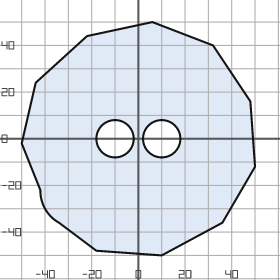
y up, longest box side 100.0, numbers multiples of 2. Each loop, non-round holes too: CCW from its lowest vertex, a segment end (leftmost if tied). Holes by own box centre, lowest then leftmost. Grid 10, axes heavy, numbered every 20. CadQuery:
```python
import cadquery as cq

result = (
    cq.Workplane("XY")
    .moveTo(10.0, -50.0)
    .lineTo(36.0, -36.0)
    .lineTo(50.0, -12.0)
    .lineTo(48.0, 16.0)
    .lineTo(32.0, 40.0)
    .lineTo(6.0, 50.0)
    .lineTo(-22.0, 44.0)
    .lineTo(-44.0, 24.0)
    .lineTo(-50.0, -2.0)
    .lineTo(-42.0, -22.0)
    .threePointArc((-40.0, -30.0), (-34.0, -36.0))
    .lineTo(-18.0, -48.0)
    .close()
    .moveTo(-10.0, 0.0)
    .circle(8.0)
    .moveTo(10.0, 0.0)
    .circle(8.0)
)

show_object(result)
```